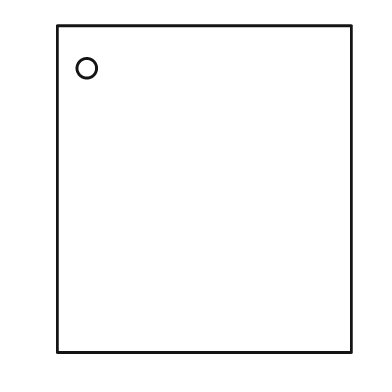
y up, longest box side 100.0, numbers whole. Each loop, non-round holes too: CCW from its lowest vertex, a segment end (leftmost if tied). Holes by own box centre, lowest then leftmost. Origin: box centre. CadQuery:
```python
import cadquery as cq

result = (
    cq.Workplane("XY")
    .moveTo(-45.0, -50.0)
    .lineTo(45.0, -50.0)
    .lineTo(45.0, 50.0)
    .lineTo(-45.0, 50.0)
    .close()
    .moveTo(-36.0, 37.0)
    .circle(3.0)
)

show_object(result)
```